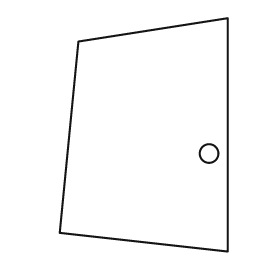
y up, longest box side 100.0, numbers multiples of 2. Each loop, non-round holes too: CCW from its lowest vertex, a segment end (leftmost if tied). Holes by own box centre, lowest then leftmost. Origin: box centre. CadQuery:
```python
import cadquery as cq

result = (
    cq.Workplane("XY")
    .moveTo(36.0, -50.0)
    .lineTo(36.0, 50.0)
    .lineTo(-28.0, 40.0)
    .lineTo(-36.0, -42.0)
    .close()
    .moveTo(28.0, -8.0)
    .circle(4.0)
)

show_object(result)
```